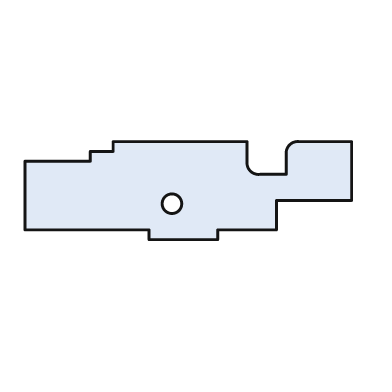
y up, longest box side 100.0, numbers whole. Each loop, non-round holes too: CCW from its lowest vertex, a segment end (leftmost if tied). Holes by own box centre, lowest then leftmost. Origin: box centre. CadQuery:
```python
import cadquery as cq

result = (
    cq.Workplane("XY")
    .moveTo(-12.0, -15.0)
    .lineTo(9.0, -15.0)
    .lineTo(9.0, -12.0)
    .lineTo(27.0, -12.0)
    .lineTo(27.0, -3.0)
    .lineTo(50.0, -3.0)
    .lineTo(50.0, 15.0)
    .lineTo(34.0, 15.0)
    .threePointArc((31.0, 14.0), (30.0, 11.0))
    .lineTo(30.0, 5.0)
    .lineTo(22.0, 5.0)
    .threePointArc((19.0, 6.0), (18.0, 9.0))
    .lineTo(18.0, 15.0)
    .lineTo(-23.0, 15.0)
    .lineTo(-23.0, 12.0)
    .lineTo(-30.0, 12.0)
    .lineTo(-30.0, 9.0)
    .lineTo(-50.0, 9.0)
    .lineTo(-50.0, -12.0)
    .lineTo(-12.0, -12.0)
    .close()
    .moveTo(-5.0, -4.0)
    .circle(3.0)
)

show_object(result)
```